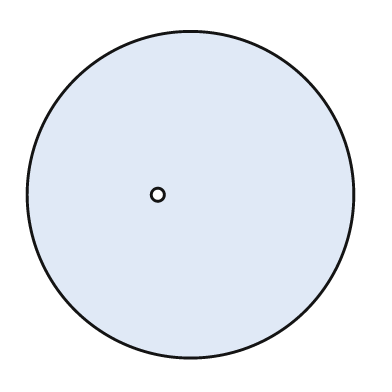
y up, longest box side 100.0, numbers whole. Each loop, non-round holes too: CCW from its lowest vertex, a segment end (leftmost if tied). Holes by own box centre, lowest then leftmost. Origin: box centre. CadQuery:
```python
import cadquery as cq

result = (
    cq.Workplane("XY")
    .moveTo(0.0, 0.0)
    .circle(50.0)
    .moveTo(-10.0, 0.0)
    .circle(2.0)
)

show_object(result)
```